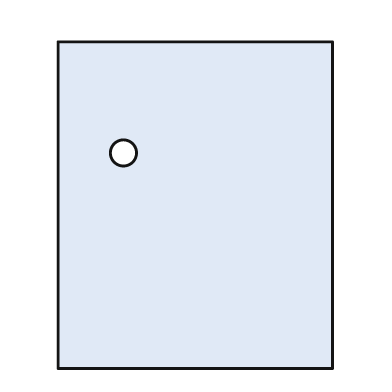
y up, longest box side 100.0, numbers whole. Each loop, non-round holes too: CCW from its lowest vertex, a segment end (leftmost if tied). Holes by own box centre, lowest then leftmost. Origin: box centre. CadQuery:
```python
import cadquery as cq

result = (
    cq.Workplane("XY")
    .moveTo(-42.0, -50.0)
    .lineTo(42.0, -50.0)
    .lineTo(42.0, 50.0)
    .lineTo(-42.0, 50.0)
    .close()
    .moveTo(-22.0, 16.0)
    .circle(4.0)
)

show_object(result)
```